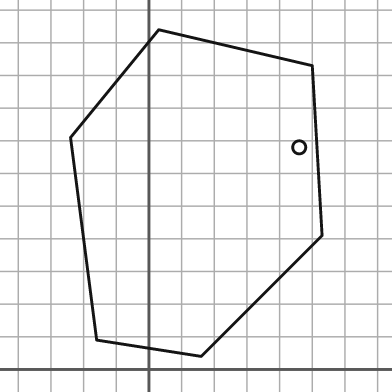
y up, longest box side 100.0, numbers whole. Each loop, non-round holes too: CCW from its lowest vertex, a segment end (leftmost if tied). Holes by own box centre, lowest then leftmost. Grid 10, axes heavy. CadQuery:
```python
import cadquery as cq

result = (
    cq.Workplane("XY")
    .moveTo(16.0, 4.0)
    .lineTo(53.0, 41.0)
    .lineTo(50.0, 93.0)
    .lineTo(3.0, 104.0)
    .lineTo(-24.0, 71.0)
    .lineTo(-16.0, 9.0)
    .close()
    .moveTo(46.0, 68.0)
    .circle(2.0)
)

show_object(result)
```